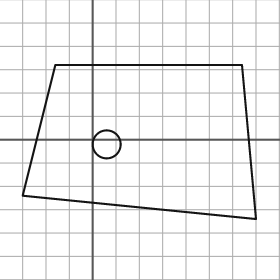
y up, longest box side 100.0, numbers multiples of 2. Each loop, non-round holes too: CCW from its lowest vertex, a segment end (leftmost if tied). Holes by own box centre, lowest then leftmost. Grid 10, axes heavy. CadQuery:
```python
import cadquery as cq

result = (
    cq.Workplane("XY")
    .moveTo(70.0, -34.0)
    .lineTo(64.0, 32.0)
    .lineTo(-16.0, 32.0)
    .lineTo(-30.0, -24.0)
    .close()
    .moveTo(6.0, -2.0)
    .circle(6.0)
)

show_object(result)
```